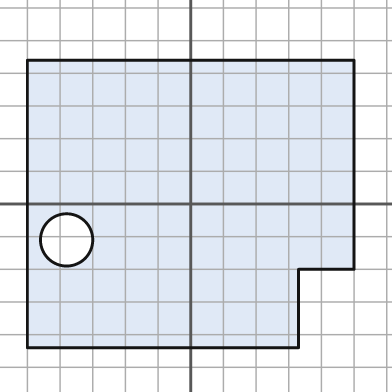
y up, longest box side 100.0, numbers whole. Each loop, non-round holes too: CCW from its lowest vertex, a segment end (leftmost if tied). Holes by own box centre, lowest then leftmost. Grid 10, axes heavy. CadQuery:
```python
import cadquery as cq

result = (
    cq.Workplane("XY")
    .moveTo(-50.0, -44.0)
    .lineTo(33.0, -44.0)
    .lineTo(33.0, -20.0)
    .lineTo(50.0, -20.0)
    .lineTo(50.0, 44.0)
    .lineTo(-50.0, 44.0)
    .close()
    .moveTo(-38.0, -11.0)
    .circle(8.0)
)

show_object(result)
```